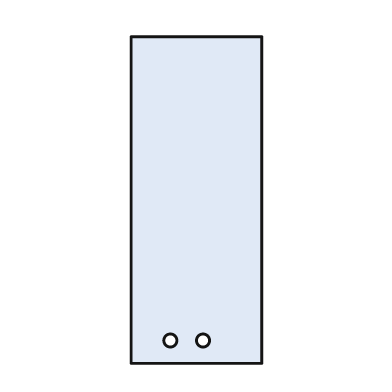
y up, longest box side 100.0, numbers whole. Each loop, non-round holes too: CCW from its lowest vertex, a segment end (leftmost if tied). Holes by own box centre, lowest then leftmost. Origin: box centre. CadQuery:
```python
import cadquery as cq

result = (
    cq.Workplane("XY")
    .moveTo(-20.0, -50.0)
    .lineTo(20.0, -50.0)
    .lineTo(20.0, 50.0)
    .lineTo(-20.0, 50.0)
    .close()
    .moveTo(-8.0, -43.0)
    .circle(2.0)
    .moveTo(2.0, -43.0)
    .circle(2.0)
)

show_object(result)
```